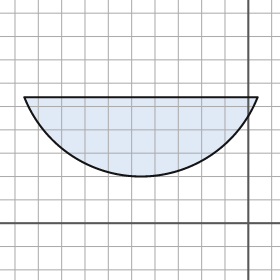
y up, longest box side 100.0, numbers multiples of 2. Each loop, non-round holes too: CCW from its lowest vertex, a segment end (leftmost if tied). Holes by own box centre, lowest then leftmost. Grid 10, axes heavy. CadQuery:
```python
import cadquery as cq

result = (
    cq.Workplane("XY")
    .moveTo(-96.0, 54.0)
    .threePointArc((-46.0, 20.0), (4.0, 54.0))
    .close()
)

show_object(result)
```